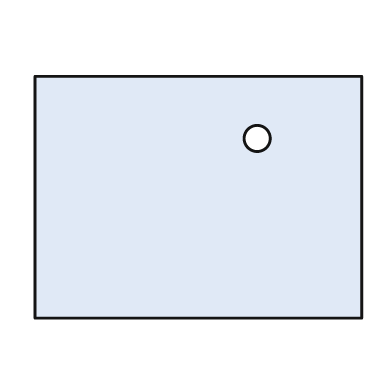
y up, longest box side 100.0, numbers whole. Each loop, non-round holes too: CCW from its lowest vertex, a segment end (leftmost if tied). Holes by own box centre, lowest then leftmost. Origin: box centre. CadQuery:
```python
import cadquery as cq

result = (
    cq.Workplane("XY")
    .moveTo(-50.0, -37.0)
    .lineTo(50.0, -37.0)
    .lineTo(50.0, 37.0)
    .lineTo(-50.0, 37.0)
    .close()
    .moveTo(18.0, 18.0)
    .circle(4.0)
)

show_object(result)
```